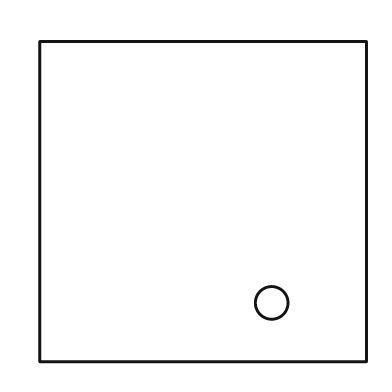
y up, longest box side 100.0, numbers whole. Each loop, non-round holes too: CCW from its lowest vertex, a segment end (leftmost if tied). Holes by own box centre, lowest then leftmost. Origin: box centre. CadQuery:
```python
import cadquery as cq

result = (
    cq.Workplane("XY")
    .moveTo(-50.0, -49.0)
    .lineTo(50.0, -49.0)
    .lineTo(50.0, 49.0)
    .lineTo(-50.0, 49.0)
    .close()
    .moveTo(21.0, -31.0)
    .circle(5.0)
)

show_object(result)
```